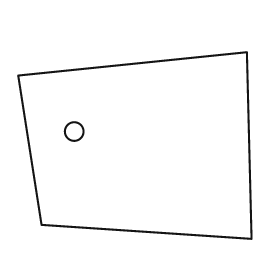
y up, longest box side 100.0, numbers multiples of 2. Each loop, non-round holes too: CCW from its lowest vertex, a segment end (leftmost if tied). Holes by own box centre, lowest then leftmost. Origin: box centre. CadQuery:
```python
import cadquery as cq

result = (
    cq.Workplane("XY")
    .moveTo(50.0, -40.0)
    .lineTo(48.0, 40.0)
    .lineTo(-50.0, 30.0)
    .lineTo(-40.0, -34.0)
    .close()
    .moveTo(-26.0, 6.0)
    .circle(4.0)
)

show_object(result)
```